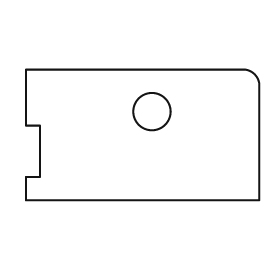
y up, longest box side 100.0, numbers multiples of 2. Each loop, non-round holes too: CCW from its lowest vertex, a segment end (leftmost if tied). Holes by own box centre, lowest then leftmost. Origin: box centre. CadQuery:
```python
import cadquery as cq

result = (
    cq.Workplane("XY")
    .moveTo(-50.0, -28.0)
    .lineTo(50.0, -28.0)
    .lineTo(50.0, 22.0)
    .threePointArc((48.0, 26.0), (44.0, 28.0))
    .lineTo(-50.0, 28.0)
    .lineTo(-50.0, 4.0)
    .lineTo(-44.0, 4.0)
    .lineTo(-44.0, -18.0)
    .lineTo(-50.0, -18.0)
    .close()
    .moveTo(4.0, 10.0)
    .circle(8.0)
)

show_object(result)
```